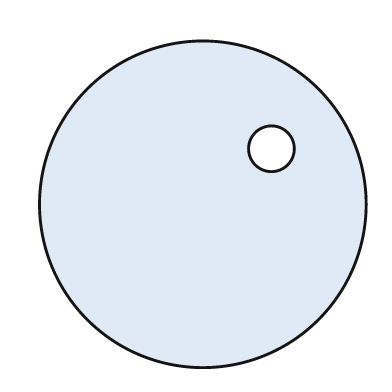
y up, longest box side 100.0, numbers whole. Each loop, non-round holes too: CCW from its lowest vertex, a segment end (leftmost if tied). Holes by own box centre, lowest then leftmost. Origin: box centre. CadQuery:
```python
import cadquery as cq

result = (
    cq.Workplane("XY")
    .moveTo(0.0, 0.0)
    .circle(50.0)
    .moveTo(21.0, 17.0)
    .circle(7.0)
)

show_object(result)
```